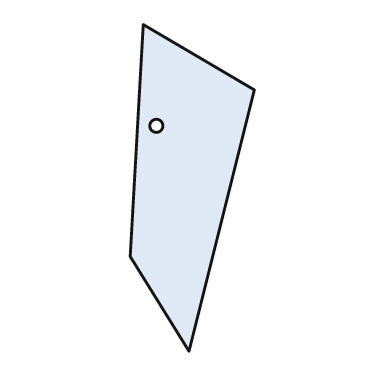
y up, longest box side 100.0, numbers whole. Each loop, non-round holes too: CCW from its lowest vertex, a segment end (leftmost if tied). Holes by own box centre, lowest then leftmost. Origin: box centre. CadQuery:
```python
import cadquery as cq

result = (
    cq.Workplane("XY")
    .moveTo(-1.0, -50.0)
    .lineTo(19.0, 30.0)
    .lineTo(-15.0, 50.0)
    .lineTo(-19.0, -21.0)
    .close()
    .moveTo(-11.0, 19.0)
    .circle(2.0)
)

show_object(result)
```